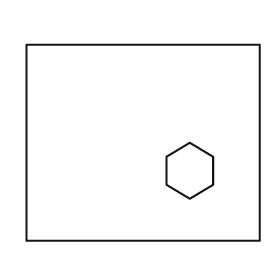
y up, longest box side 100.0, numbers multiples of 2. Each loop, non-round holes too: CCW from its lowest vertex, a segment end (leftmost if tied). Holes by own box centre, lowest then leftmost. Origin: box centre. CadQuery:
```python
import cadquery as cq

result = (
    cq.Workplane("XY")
    .moveTo(-50.0, -42.0)
    .lineTo(50.0, -42.0)
    .lineTo(50.0, 42.0)
    .lineTo(-50.0, 42.0)
    .close()
    .moveTo(20.0, -24.0)
    .lineTo(30.0, -18.0)
    .lineTo(30.0, -6.0)
    .lineTo(20.0, 0.0)
    .lineTo(10.0, -6.0)
    .lineTo(10.0, -18.0)
    .close()
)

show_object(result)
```